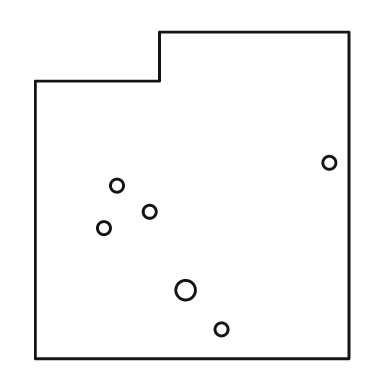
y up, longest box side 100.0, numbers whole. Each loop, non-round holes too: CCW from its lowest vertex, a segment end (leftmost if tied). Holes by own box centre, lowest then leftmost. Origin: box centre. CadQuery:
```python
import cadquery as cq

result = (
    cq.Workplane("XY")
    .moveTo(-48.0, -50.0)
    .lineTo(48.0, -50.0)
    .lineTo(48.0, 50.0)
    .lineTo(-10.0, 50.0)
    .lineTo(-10.0, 35.0)
    .lineTo(-48.0, 35.0)
    .close()
    .moveTo(9.0, -41.0)
    .circle(2.0)
    .moveTo(-2.0, -29.0)
    .circle(3.0)
    .moveTo(-27.0, -10.0)
    .circle(2.0)
    .moveTo(-13.0, -5.0)
    .circle(2.0)
    .moveTo(-23.0, 3.0)
    .circle(2.0)
    .moveTo(42.0, 10.0)
    .circle(2.0)
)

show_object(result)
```